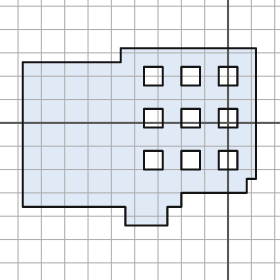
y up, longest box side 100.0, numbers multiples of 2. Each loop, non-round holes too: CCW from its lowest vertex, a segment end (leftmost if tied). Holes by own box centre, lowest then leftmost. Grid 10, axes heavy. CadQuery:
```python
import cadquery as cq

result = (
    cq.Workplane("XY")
    .moveTo(-44.0, -44.0)
    .lineTo(-26.0, -44.0)
    .lineTo(-26.0, -36.0)
    .lineTo(-20.0, -36.0)
    .lineTo(-20.0, -30.0)
    .lineTo(8.0, -30.0)
    .lineTo(8.0, -24.0)
    .lineTo(12.0, -24.0)
    .lineTo(12.0, 32.0)
    .lineTo(-46.0, 32.0)
    .lineTo(-46.0, 26.0)
    .lineTo(-88.0, 26.0)
    .lineTo(-88.0, -36.0)
    .lineTo(-44.0, -36.0)
    .close()
    .moveTo(-36.0, -20.0)
    .lineTo(-28.0, -20.0)
    .lineTo(-28.0, -12.0)
    .lineTo(-36.0, -12.0)
    .close()
    .moveTo(-20.0, -20.0)
    .lineTo(-12.0, -20.0)
    .lineTo(-12.0, -12.0)
    .lineTo(-20.0, -12.0)
    .close()
    .moveTo(-4.0, -20.0)
    .lineTo(4.0, -20.0)
    .lineTo(4.0, -12.0)
    .lineTo(-4.0, -12.0)
    .close()
    .moveTo(-36.0, -2.0)
    .lineTo(-28.0, -2.0)
    .lineTo(-28.0, 6.0)
    .lineTo(-36.0, 6.0)
    .close()
    .moveTo(-20.0, -2.0)
    .lineTo(-12.0, -2.0)
    .lineTo(-12.0, 6.0)
    .lineTo(-20.0, 6.0)
    .close()
    .moveTo(-4.0, -2.0)
    .lineTo(4.0, -2.0)
    .lineTo(4.0, 6.0)
    .lineTo(-4.0, 6.0)
    .close()
    .moveTo(-36.0, 16.0)
    .lineTo(-28.0, 16.0)
    .lineTo(-28.0, 24.0)
    .lineTo(-36.0, 24.0)
    .close()
    .moveTo(-20.0, 16.0)
    .lineTo(-12.0, 16.0)
    .lineTo(-12.0, 24.0)
    .lineTo(-20.0, 24.0)
    .close()
    .moveTo(-4.0, 16.0)
    .lineTo(4.0, 16.0)
    .lineTo(4.0, 24.0)
    .lineTo(-4.0, 24.0)
    .close()
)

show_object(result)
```